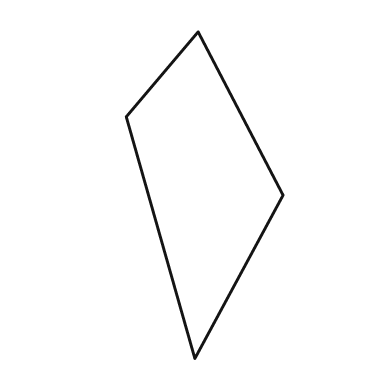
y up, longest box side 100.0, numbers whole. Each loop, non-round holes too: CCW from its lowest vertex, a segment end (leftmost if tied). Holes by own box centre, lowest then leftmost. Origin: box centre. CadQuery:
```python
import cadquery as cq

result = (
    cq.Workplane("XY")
    .moveTo(-3.0, -50.0)
    .lineTo(24.0, 0.0)
    .lineTo(-2.0, 50.0)
    .lineTo(-24.0, 24.0)
    .close()
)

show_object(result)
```